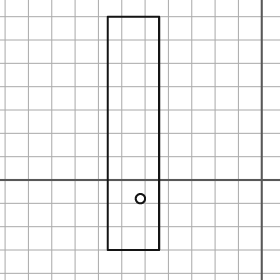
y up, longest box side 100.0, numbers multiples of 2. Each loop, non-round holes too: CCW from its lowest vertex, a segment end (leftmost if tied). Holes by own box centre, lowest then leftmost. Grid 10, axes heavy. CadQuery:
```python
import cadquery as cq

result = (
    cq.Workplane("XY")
    .moveTo(-66.0, -30.0)
    .lineTo(-44.0, -30.0)
    .lineTo(-44.0, 70.0)
    .lineTo(-66.0, 70.0)
    .close()
    .moveTo(-52.0, -8.0)
    .circle(2.0)
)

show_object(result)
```